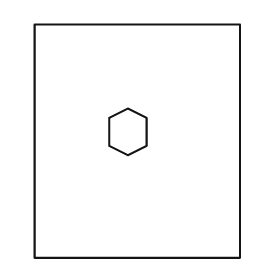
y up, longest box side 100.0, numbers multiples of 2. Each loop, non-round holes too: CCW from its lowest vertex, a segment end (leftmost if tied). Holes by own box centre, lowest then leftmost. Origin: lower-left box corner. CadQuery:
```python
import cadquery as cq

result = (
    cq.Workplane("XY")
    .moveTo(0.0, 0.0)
    .lineTo(88.0, 0.0)
    .lineTo(88.0, 100.0)
    .lineTo(0.0, 100.0)
    .close()
    .moveTo(40.0, 44.0)
    .lineTo(48.0, 48.0)
    .lineTo(48.0, 60.0)
    .lineTo(40.0, 64.0)
    .lineTo(32.0, 60.0)
    .lineTo(32.0, 48.0)
    .close()
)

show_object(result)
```